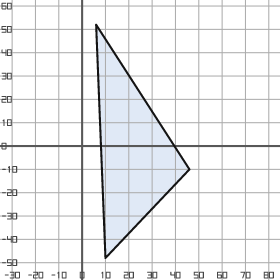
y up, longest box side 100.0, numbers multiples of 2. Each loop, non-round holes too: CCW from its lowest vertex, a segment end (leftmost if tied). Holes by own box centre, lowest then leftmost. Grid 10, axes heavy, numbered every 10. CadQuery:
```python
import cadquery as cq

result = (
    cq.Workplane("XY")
    .moveTo(10.0, -48.0)
    .lineTo(46.0, -10.0)
    .lineTo(6.0, 52.0)
    .close()
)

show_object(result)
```